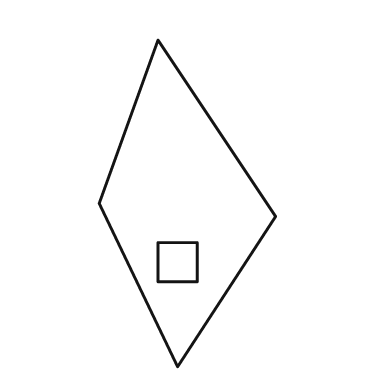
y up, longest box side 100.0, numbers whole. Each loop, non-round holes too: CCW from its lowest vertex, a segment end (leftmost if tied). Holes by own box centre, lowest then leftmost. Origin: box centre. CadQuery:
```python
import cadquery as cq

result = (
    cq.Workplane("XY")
    .moveTo(-3.0, -50.0)
    .lineTo(27.0, -4.0)
    .lineTo(-9.0, 50.0)
    .lineTo(-27.0, 0.0)
    .close()
    .moveTo(-9.0, -24.0)
    .lineTo(3.0, -24.0)
    .lineTo(3.0, -12.0)
    .lineTo(-9.0, -12.0)
    .close()
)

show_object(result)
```